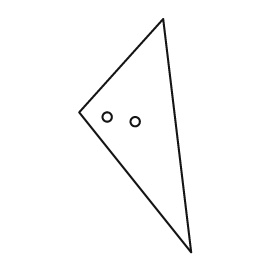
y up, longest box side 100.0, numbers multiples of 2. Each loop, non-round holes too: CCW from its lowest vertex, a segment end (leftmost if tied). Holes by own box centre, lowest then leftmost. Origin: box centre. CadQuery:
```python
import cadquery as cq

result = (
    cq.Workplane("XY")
    .moveTo(24.0, -50.0)
    .lineTo(12.0, 50.0)
    .lineTo(-24.0, 10.0)
    .close()
    .moveTo(0.0, 6.0)
    .circle(2.0)
    .moveTo(-12.0, 8.0)
    .circle(2.0)
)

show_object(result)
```